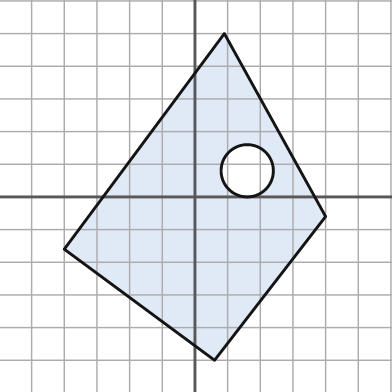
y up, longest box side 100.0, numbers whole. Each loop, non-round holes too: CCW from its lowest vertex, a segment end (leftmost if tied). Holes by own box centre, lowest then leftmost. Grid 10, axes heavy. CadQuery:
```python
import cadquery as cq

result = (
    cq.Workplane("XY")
    .moveTo(6.0, -50.0)
    .lineTo(40.0, -6.0)
    .lineTo(9.0, 50.0)
    .lineTo(-40.0, -16.0)
    .close()
    .moveTo(16.0, 8.0)
    .circle(8.0)
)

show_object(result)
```